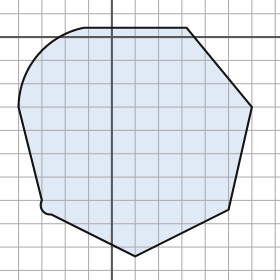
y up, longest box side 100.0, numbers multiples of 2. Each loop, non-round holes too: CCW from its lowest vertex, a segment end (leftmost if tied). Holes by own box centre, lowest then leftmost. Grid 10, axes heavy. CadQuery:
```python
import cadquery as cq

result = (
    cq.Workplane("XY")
    .moveTo(10.0, -94.0)
    .lineTo(50.0, -74.0)
    .lineTo(60.0, -30.0)
    .lineTo(32.0, 4.0)
    .lineTo(-12.0, 4.0)
    .threePointArc((-32.0, -8.0), (-40.0, -30.0))
    .lineTo(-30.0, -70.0)
    .threePointArc((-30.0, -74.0), (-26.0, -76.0))
    .close()
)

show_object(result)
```